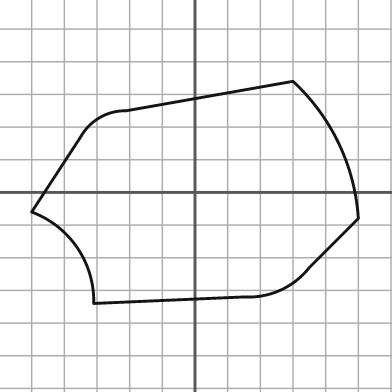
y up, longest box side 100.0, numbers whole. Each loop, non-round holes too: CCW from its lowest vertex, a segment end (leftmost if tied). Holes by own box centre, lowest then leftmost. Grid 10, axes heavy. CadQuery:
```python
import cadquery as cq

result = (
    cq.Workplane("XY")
    .moveTo(-31.0, -34.0)
    .lineTo(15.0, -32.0)
    .threePointArc((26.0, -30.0), (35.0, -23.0))
    .lineTo(50.0, -8.0)
    .threePointArc((44.0, 15.0), (30.0, 34.0))
    .lineTo(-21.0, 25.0)
    .threePointArc((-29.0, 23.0), (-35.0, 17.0))
    .lineTo(-50.0, -6.0)
    .threePointArc((-36.0, -17.0), (-31.0, -34.0))
    .close()
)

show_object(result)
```